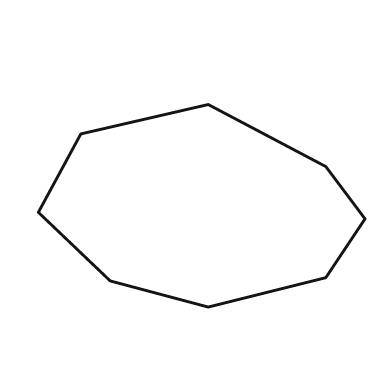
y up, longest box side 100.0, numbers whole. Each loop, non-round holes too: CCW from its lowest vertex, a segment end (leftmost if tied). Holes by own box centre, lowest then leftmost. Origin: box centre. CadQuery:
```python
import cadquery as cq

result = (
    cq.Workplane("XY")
    .moveTo(2.0, -31.0)
    .lineTo(38.0, -22.0)
    .lineTo(50.0, -4.0)
    .lineTo(38.0, 12.0)
    .lineTo(2.0, 31.0)
    .lineTo(-37.0, 22.0)
    .lineTo(-50.0, -2.0)
    .lineTo(-28.0, -23.0)
    .close()
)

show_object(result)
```